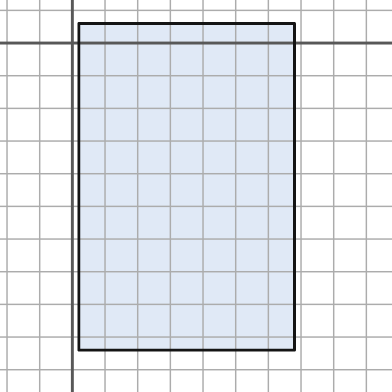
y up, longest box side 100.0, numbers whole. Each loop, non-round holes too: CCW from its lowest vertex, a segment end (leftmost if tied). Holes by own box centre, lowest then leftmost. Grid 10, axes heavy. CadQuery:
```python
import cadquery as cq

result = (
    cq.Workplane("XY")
    .moveTo(2.0, -94.0)
    .lineTo(68.0, -94.0)
    .lineTo(68.0, 6.0)
    .lineTo(2.0, 6.0)
    .close()
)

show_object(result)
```